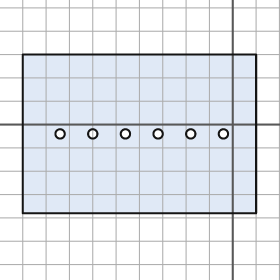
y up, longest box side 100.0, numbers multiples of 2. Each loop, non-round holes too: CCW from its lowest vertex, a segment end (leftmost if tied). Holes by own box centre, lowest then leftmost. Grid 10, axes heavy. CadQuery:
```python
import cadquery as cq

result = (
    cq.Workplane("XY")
    .moveTo(-90.0, -38.0)
    .lineTo(10.0, -38.0)
    .lineTo(10.0, 30.0)
    .lineTo(-90.0, 30.0)
    .close()
    .moveTo(-74.0, -4.0)
    .circle(2.0)
    .moveTo(-60.0, -4.0)
    .circle(2.0)
    .moveTo(-46.0, -4.0)
    .circle(2.0)
    .moveTo(-32.0, -4.0)
    .circle(2.0)
    .moveTo(-18.0, -4.0)
    .circle(2.0)
    .moveTo(-4.0, -4.0)
    .circle(2.0)
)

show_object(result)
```